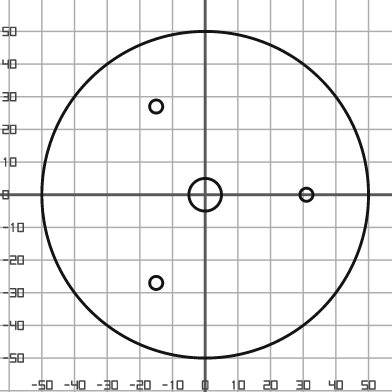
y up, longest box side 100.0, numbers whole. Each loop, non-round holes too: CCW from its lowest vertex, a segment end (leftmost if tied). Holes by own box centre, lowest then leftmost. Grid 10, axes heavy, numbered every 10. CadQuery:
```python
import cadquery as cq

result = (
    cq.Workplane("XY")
    .moveTo(0.0, 0.0)
    .circle(50.0)
    .moveTo(-15.0, -27.0)
    .circle(2.0)
    .moveTo(0.0, 0.0)
    .circle(5.0)
    .moveTo(31.0, 0.0)
    .circle(2.0)
    .moveTo(-15.0, 27.0)
    .circle(2.0)
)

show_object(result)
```